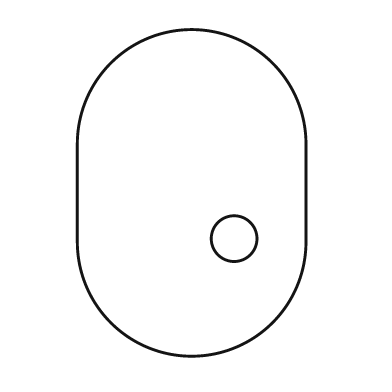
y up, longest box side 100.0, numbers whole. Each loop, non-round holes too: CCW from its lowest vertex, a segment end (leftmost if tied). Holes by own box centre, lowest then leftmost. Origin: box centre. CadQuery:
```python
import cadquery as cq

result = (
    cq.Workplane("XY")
    .moveTo(-35.0, -15.0)
    .threePointArc((0.0, -50.0), (35.0, -15.0))
    .lineTo(35.0, 15.0)
    .threePointArc((0.0, 50.0), (-35.0, 15.0))
    .close()
    .moveTo(13.0, -14.0)
    .circle(7.0)
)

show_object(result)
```